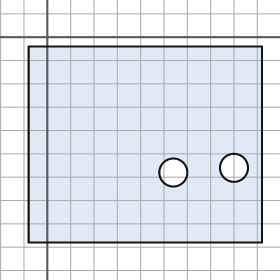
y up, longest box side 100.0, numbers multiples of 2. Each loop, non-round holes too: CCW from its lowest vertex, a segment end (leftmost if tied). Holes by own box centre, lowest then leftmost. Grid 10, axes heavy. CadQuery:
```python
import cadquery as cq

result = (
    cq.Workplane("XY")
    .moveTo(-8.0, -88.0)
    .lineTo(92.0, -88.0)
    .lineTo(92.0, -4.0)
    .lineTo(-8.0, -4.0)
    .close()
    .moveTo(54.0, -58.0)
    .circle(6.0)
    .moveTo(80.0, -56.0)
    .circle(6.0)
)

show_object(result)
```